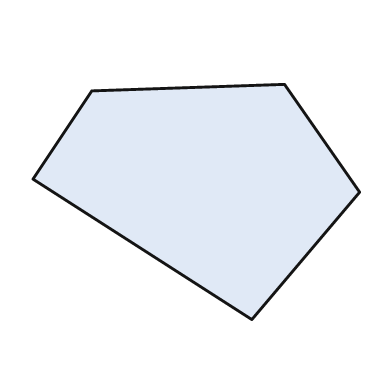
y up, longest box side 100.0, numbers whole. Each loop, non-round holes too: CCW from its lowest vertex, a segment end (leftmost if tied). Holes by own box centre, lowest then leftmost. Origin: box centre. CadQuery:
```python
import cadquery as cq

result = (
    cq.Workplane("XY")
    .moveTo(17.0, -36.0)
    .lineTo(50.0, 3.0)
    .lineTo(27.0, 36.0)
    .lineTo(-32.0, 34.0)
    .lineTo(-50.0, 7.0)
    .close()
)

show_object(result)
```